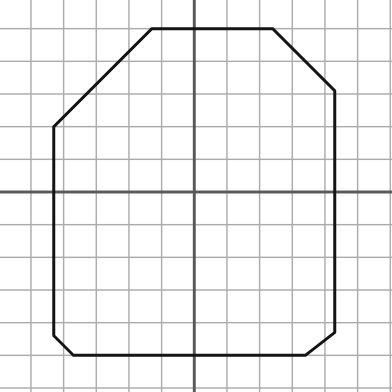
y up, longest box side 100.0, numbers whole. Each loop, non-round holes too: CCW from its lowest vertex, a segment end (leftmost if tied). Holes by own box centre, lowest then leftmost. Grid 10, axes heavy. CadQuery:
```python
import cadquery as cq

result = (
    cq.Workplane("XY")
    .moveTo(-37.0, -50.0)
    .lineTo(34.0, -50.0)
    .lineTo(43.0, -43.0)
    .lineTo(43.0, 31.0)
    .lineTo(24.0, 50.0)
    .lineTo(-13.0, 50.0)
    .lineTo(-43.0, 20.0)
    .lineTo(-43.0, -44.0)
    .close()
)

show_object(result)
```